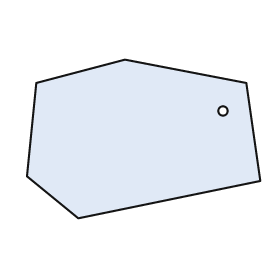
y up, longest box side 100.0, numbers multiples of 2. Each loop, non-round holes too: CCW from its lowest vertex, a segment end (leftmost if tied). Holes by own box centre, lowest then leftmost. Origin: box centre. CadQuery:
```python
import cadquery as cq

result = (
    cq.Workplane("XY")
    .moveTo(-28.0, -34.0)
    .lineTo(50.0, -18.0)
    .lineTo(44.0, 24.0)
    .lineTo(-8.0, 34.0)
    .lineTo(-46.0, 24.0)
    .lineTo(-50.0, -16.0)
    .close()
    .moveTo(34.0, 12.0)
    .circle(2.0)
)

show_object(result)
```